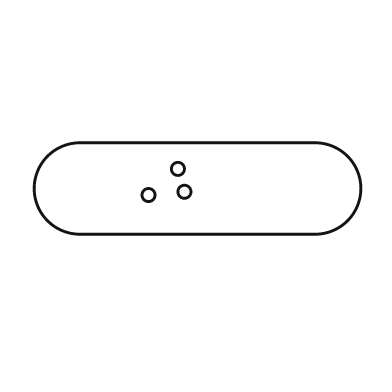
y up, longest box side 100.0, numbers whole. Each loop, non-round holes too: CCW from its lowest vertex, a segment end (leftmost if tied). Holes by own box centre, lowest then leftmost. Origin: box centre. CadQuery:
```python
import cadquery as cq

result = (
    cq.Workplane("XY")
    .moveTo(-36.0, -14.0)
    .lineTo(36.0, -14.0)
    .threePointArc((50.0, 0.0), (36.0, 14.0))
    .lineTo(-36.0, 14.0)
    .threePointArc((-50.0, 0.0), (-36.0, -14.0))
    .close()
    .moveTo(-15.0, -2.0)
    .circle(2.0)
    .moveTo(-4.0, -1.0)
    .circle(2.0)
    .moveTo(-6.0, 6.0)
    .circle(2.0)
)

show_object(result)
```